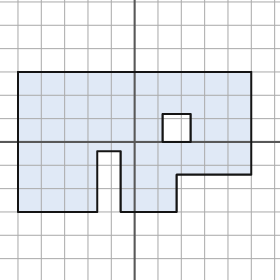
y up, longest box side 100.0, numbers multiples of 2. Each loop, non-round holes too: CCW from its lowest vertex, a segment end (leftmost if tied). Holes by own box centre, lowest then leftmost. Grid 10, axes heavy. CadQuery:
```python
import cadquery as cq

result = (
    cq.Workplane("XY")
    .moveTo(-50.0, -30.0)
    .lineTo(-16.0, -30.0)
    .lineTo(-16.0, -4.0)
    .lineTo(-6.0, -4.0)
    .lineTo(-6.0, -30.0)
    .lineTo(18.0, -30.0)
    .lineTo(18.0, -14.0)
    .lineTo(50.0, -14.0)
    .lineTo(50.0, 30.0)
    .lineTo(-50.0, 30.0)
    .close()
    .moveTo(12.0, 0.0)
    .lineTo(24.0, 0.0)
    .lineTo(24.0, 12.0)
    .lineTo(12.0, 12.0)
    .close()
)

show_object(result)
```